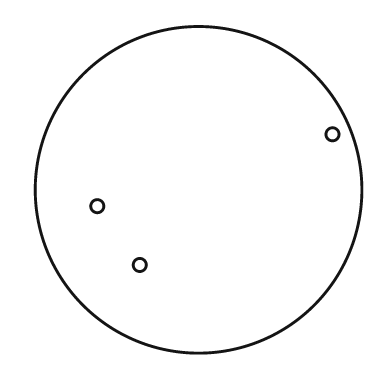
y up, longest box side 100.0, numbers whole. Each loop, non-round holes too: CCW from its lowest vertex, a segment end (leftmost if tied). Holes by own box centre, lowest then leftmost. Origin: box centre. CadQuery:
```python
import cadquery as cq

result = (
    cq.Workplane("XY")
    .moveTo(0.0, 0.0)
    .circle(50.0)
    .moveTo(-18.0, -23.0)
    .circle(2.0)
    .moveTo(-31.0, -5.0)
    .circle(2.0)
    .moveTo(41.0, 17.0)
    .circle(2.0)
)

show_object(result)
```